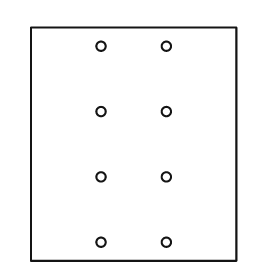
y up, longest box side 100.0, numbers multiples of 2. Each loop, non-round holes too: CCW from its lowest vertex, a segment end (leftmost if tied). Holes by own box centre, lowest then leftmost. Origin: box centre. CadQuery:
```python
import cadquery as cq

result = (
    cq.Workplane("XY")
    .moveTo(-44.0, -50.0)
    .lineTo(44.0, -50.0)
    .lineTo(44.0, 50.0)
    .lineTo(-44.0, 50.0)
    .close()
    .moveTo(-14.0, -42.0)
    .circle(2.0)
    .moveTo(14.0, -42.0)
    .circle(2.0)
    .moveTo(-14.0, -14.0)
    .circle(2.0)
    .moveTo(14.0, -14.0)
    .circle(2.0)
    .moveTo(-14.0, 14.0)
    .circle(2.0)
    .moveTo(14.0, 14.0)
    .circle(2.0)
    .moveTo(-14.0, 42.0)
    .circle(2.0)
    .moveTo(14.0, 42.0)
    .circle(2.0)
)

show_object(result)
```